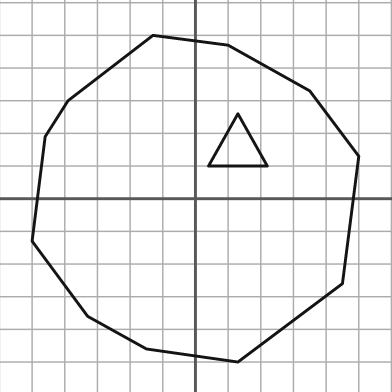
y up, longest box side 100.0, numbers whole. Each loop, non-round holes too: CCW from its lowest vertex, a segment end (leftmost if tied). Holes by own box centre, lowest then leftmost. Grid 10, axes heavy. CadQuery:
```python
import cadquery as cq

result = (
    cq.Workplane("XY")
    .moveTo(13.0, -50.0)
    .lineTo(45.0, -26.0)
    .lineTo(50.0, 13.0)
    .lineTo(35.0, 33.0)
    .lineTo(10.0, 47.0)
    .lineTo(-13.0, 50.0)
    .lineTo(-39.0, 30.0)
    .lineTo(-46.0, 19.0)
    .lineTo(-50.0, -13.0)
    .lineTo(-33.0, -36.0)
    .lineTo(-15.0, -46.0)
    .close()
    .moveTo(4.0, 10.0)
    .lineTo(22.0, 10.0)
    .lineTo(13.0, 26.0)
    .close()
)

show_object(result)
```